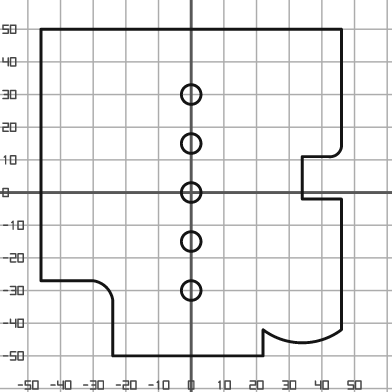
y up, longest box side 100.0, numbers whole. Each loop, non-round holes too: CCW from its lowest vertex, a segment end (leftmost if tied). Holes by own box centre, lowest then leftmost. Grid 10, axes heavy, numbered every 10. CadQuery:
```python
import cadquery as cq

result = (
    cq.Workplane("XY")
    .moveTo(-24.0, -50.0)
    .lineTo(22.0, -50.0)
    .lineTo(22.0, -42.0)
    .threePointArc((34.0, -46.0), (46.0, -42.0))
    .lineTo(46.0, -2.0)
    .lineTo(34.0, -2.0)
    .lineTo(34.0, 11.0)
    .lineTo(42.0, 11.0)
    .threePointArc((45.0, 12.0), (46.0, 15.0))
    .lineTo(46.0, 50.0)
    .lineTo(-46.0, 50.0)
    .lineTo(-46.0, -27.0)
    .lineTo(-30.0, -27.0)
    .threePointArc((-26.0, -29.0), (-24.0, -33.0))
    .close()
    .moveTo(0.0, -30.0)
    .circle(3.0)
    .moveTo(0.0, -15.0)
    .circle(3.0)
    .moveTo(0.0, 0.0)
    .circle(3.0)
    .moveTo(0.0, 15.0)
    .circle(3.0)
    .moveTo(0.0, 30.0)
    .circle(3.0)
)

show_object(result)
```